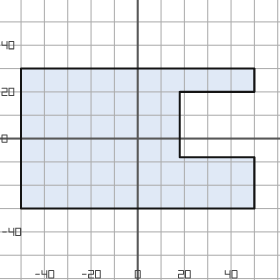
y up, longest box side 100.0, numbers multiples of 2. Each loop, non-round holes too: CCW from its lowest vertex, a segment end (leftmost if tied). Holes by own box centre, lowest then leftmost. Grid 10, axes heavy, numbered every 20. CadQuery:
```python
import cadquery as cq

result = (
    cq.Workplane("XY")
    .moveTo(-50.0, -30.0)
    .lineTo(50.0, -30.0)
    .lineTo(50.0, -8.0)
    .lineTo(18.0, -8.0)
    .lineTo(18.0, 20.0)
    .lineTo(50.0, 20.0)
    .lineTo(50.0, 30.0)
    .lineTo(-50.0, 30.0)
    .close()
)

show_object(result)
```